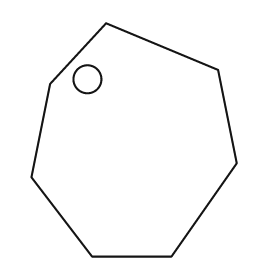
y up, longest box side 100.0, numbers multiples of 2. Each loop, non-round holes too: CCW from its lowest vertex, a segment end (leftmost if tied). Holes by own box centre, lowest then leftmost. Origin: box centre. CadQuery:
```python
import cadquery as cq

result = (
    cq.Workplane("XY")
    .moveTo(-18.0, -50.0)
    .lineTo(16.0, -50.0)
    .lineTo(44.0, -10.0)
    .lineTo(36.0, 30.0)
    .lineTo(-12.0, 50.0)
    .lineTo(-36.0, 24.0)
    .lineTo(-44.0, -16.0)
    .close()
    .moveTo(-20.0, 26.0)
    .circle(6.0)
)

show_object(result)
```